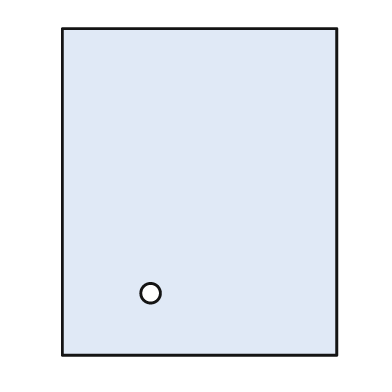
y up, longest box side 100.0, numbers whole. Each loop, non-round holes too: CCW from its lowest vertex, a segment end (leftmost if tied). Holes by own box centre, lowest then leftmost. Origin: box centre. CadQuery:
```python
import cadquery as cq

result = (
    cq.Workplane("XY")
    .moveTo(-42.0, -50.0)
    .lineTo(42.0, -50.0)
    .lineTo(42.0, 50.0)
    .lineTo(-42.0, 50.0)
    .close()
    .moveTo(-15.0, -31.0)
    .circle(3.0)
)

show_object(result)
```